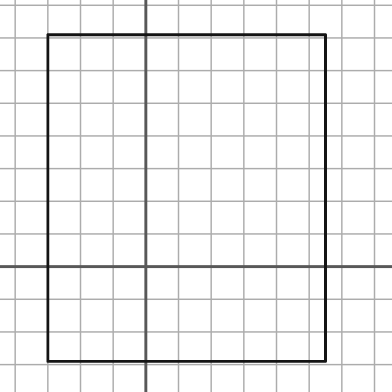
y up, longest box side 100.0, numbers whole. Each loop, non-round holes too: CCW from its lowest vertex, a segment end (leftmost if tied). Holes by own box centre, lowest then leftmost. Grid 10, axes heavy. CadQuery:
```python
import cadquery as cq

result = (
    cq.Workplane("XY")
    .moveTo(-30.0, -29.0)
    .lineTo(55.0, -29.0)
    .lineTo(55.0, 71.0)
    .lineTo(-30.0, 71.0)
    .close()
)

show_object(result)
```